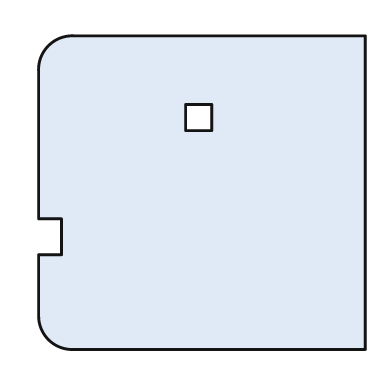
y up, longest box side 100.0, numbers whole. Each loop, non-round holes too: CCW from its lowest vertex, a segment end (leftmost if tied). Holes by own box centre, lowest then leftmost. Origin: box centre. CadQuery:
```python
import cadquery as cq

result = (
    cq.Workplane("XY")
    .moveTo(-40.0, -48.0)
    .lineTo(50.0, -48.0)
    .lineTo(50.0, 48.0)
    .lineTo(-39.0, 48.0)
    .threePointArc((-47.0, 45.0), (-50.0, 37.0))
    .lineTo(-50.0, -8.0)
    .lineTo(-43.0, -8.0)
    .lineTo(-43.0, -19.0)
    .lineTo(-50.0, -19.0)
    .lineTo(-50.0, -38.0)
    .threePointArc((-47.0, -45.0), (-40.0, -48.0))
    .close()
    .moveTo(-5.0, 19.0)
    .lineTo(3.0, 19.0)
    .lineTo(3.0, 27.0)
    .lineTo(-5.0, 27.0)
    .close()
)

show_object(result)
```